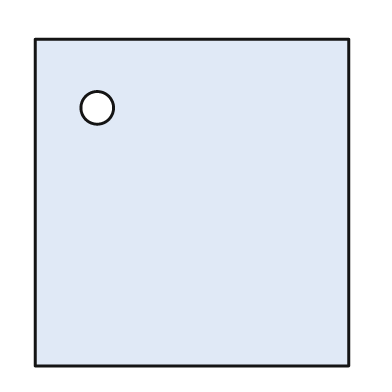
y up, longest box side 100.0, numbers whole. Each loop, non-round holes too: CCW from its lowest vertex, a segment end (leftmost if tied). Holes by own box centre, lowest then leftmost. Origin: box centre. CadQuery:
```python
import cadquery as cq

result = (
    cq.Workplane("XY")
    .moveTo(-48.0, -50.0)
    .lineTo(48.0, -50.0)
    .lineTo(48.0, 50.0)
    .lineTo(-48.0, 50.0)
    .close()
    .moveTo(-29.0, 29.0)
    .circle(5.0)
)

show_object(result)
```